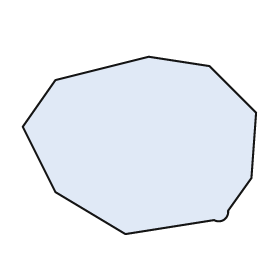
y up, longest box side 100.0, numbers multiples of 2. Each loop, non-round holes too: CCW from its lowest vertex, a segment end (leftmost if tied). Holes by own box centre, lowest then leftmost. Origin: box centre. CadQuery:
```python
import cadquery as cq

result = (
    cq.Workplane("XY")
    .moveTo(-6.0, -38.0)
    .lineTo(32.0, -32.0)
    .threePointArc((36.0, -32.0), (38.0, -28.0))
    .lineTo(48.0, -14.0)
    .lineTo(50.0, 14.0)
    .lineTo(30.0, 34.0)
    .lineTo(4.0, 38.0)
    .lineTo(-36.0, 28.0)
    .lineTo(-50.0, 8.0)
    .lineTo(-36.0, -20.0)
    .close()
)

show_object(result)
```